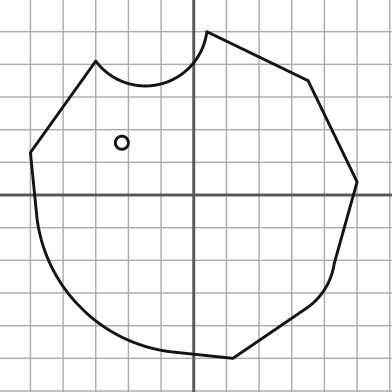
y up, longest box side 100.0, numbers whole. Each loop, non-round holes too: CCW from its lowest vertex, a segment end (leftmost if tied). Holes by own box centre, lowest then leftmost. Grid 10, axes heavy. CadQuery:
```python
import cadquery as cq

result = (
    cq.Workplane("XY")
    .moveTo(12.0, -50.0)
    .lineTo(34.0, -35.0)
    .threePointArc((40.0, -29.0), (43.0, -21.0))
    .lineTo(50.0, 4.0)
    .lineTo(35.0, 35.0)
    .lineTo(4.0, 50.0)
    .threePointArc((-10.0, 34.0), (-30.0, 41.0))
    .lineTo(-50.0, 13.0)
    .lineTo(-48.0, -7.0)
    .threePointArc((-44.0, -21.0), (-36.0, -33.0))
    .lineTo(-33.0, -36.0)
    .threePointArc((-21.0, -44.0), (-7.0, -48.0))
    .close()
    .moveTo(-22.0, 16.0)
    .circle(2.0)
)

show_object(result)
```